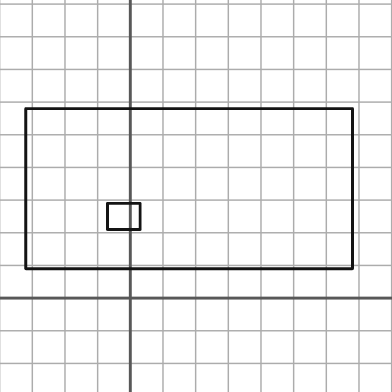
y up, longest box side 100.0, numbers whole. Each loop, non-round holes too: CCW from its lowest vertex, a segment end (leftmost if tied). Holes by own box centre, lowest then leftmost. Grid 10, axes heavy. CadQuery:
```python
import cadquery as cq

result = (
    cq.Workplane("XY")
    .moveTo(-32.0, 9.0)
    .lineTo(68.0, 9.0)
    .lineTo(68.0, 58.0)
    .lineTo(-32.0, 58.0)
    .close()
    .moveTo(-7.0, 21.0)
    .lineTo(3.0, 21.0)
    .lineTo(3.0, 29.0)
    .lineTo(-7.0, 29.0)
    .close()
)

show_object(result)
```